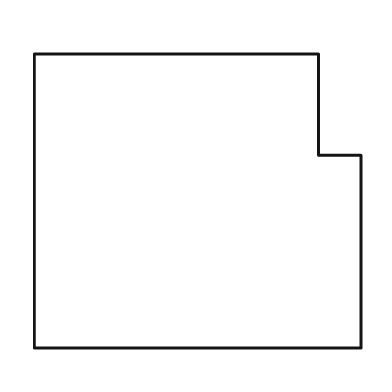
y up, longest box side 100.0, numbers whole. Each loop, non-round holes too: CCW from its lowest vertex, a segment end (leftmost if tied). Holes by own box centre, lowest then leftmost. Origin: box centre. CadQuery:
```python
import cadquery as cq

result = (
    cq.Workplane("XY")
    .moveTo(-50.0, -45.0)
    .lineTo(50.0, -45.0)
    .lineTo(50.0, 14.0)
    .lineTo(37.0, 14.0)
    .lineTo(37.0, 45.0)
    .lineTo(-50.0, 45.0)
    .close()
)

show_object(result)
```